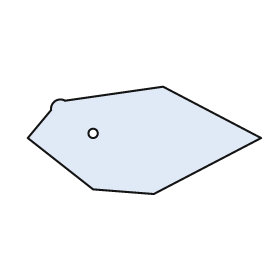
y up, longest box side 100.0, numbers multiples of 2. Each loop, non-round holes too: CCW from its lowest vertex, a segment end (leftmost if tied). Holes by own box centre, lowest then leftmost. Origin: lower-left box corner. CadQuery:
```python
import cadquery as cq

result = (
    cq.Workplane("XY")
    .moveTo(54.0, 0.0)
    .lineTo(100.0, 24.0)
    .lineTo(58.0, 46.0)
    .lineTo(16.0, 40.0)
    .threePointArc((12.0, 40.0), (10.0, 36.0))
    .lineTo(0.0, 24.0)
    .lineTo(28.0, 2.0)
    .close()
    .moveTo(28.0, 26.0)
    .circle(2.0)
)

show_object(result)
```